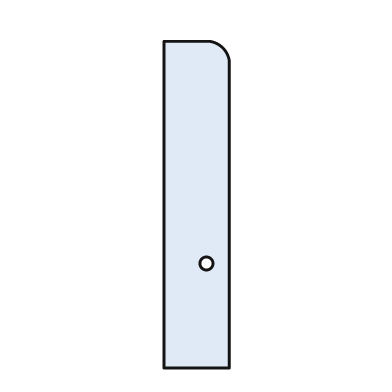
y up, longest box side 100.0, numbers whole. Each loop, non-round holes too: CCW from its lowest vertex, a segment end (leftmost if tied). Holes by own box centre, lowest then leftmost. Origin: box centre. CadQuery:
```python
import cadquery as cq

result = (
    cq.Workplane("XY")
    .moveTo(-10.0, -50.0)
    .lineTo(10.0, -50.0)
    .lineTo(10.0, 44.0)
    .threePointArc((8.0, 48.0), (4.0, 50.0))
    .lineTo(-10.0, 50.0)
    .close()
    .moveTo(3.0, -18.0)
    .circle(2.0)
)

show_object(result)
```